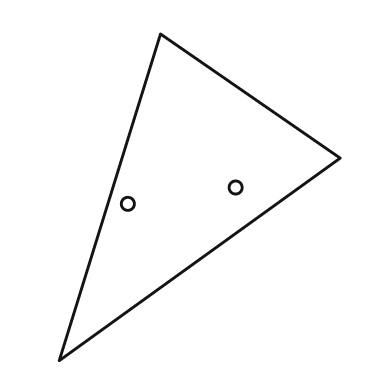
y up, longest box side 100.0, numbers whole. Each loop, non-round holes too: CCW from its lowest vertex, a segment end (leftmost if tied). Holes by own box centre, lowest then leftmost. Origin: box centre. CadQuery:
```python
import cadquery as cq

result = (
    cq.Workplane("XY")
    .moveTo(-43.0, -50.0)
    .lineTo(43.0, 12.0)
    .lineTo(-12.0, 50.0)
    .close()
    .moveTo(-22.0, -2.0)
    .circle(2.0)
    .moveTo(11.0, 3.0)
    .circle(2.0)
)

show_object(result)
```